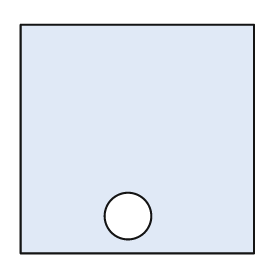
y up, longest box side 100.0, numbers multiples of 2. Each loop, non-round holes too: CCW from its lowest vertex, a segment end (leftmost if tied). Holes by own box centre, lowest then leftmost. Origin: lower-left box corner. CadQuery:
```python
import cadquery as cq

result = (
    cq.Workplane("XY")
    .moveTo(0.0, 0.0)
    .lineTo(100.0, 0.0)
    .lineTo(100.0, 98.0)
    .lineTo(0.0, 98.0)
    .close()
    .moveTo(46.0, 16.0)
    .circle(10.0)
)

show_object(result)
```